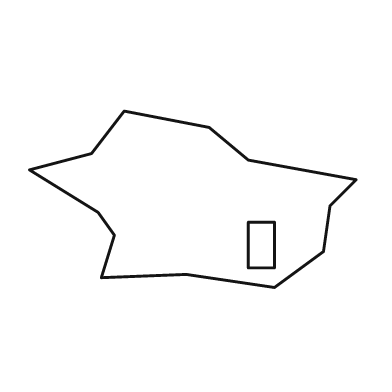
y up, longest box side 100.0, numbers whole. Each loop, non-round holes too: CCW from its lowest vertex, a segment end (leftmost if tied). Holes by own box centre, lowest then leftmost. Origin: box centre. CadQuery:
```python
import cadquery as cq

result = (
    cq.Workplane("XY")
    .moveTo(25.0, -27.0)
    .lineTo(40.0, -16.0)
    .lineTo(42.0, -2.0)
    .lineTo(50.0, 6.0)
    .lineTo(17.0, 12.0)
    .lineTo(5.0, 22.0)
    .lineTo(-21.0, 27.0)
    .lineTo(-31.0, 14.0)
    .lineTo(-50.0, 9.0)
    .lineTo(-29.0, -4.0)
    .lineTo(-24.0, -11.0)
    .lineTo(-28.0, -24.0)
    .lineTo(-2.0, -23.0)
    .close()
    .moveTo(17.0, -21.0)
    .lineTo(25.0, -21.0)
    .lineTo(25.0, -7.0)
    .lineTo(17.0, -7.0)
    .close()
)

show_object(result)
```